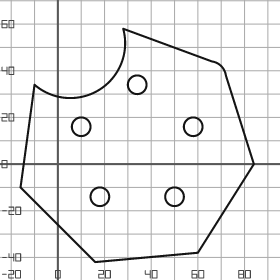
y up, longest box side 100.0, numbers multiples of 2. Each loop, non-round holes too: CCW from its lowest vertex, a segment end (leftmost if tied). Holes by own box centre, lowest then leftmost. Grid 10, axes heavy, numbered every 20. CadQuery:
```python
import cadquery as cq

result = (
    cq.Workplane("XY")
    .moveTo(16.0, -42.0)
    .lineTo(60.0, -38.0)
    .lineTo(84.0, 0.0)
    .lineTo(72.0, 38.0)
    .threePointArc((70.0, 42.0), (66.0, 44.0))
    .lineTo(28.0, 58.0)
    .threePointArc((18.0, 32.0), (-10.0, 34.0))
    .lineTo(-16.0, -10.0)
    .close()
    .moveTo(18.0, -14.0)
    .circle(4.0)
    .moveTo(50.0, -14.0)
    .circle(4.0)
    .moveTo(10.0, 16.0)
    .circle(4.0)
    .moveTo(58.0, 16.0)
    .circle(4.0)
    .moveTo(34.0, 34.0)
    .circle(4.0)
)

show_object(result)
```